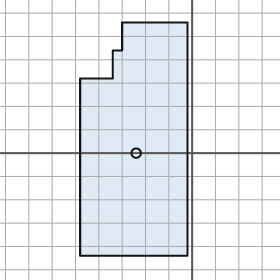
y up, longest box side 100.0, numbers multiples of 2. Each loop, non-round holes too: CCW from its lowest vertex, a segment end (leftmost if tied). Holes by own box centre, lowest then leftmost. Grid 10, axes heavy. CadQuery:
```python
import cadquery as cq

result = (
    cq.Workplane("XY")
    .moveTo(-48.0, -44.0)
    .lineTo(-2.0, -44.0)
    .lineTo(-2.0, 56.0)
    .lineTo(-30.0, 56.0)
    .lineTo(-30.0, 44.0)
    .lineTo(-34.0, 44.0)
    .lineTo(-34.0, 32.0)
    .lineTo(-48.0, 32.0)
    .close()
    .moveTo(-24.0, 0.0)
    .circle(2.0)
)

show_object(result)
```